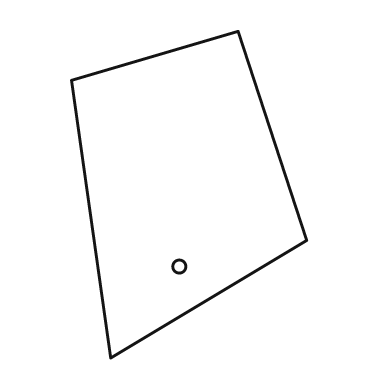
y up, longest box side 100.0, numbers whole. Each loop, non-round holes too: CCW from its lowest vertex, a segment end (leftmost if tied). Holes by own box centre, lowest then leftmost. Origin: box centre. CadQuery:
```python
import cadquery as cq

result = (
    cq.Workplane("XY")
    .moveTo(-24.0, -50.0)
    .lineTo(36.0, -14.0)
    .lineTo(15.0, 50.0)
    .lineTo(-36.0, 35.0)
    .close()
    .moveTo(-3.0, -22.0)
    .circle(2.0)
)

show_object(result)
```